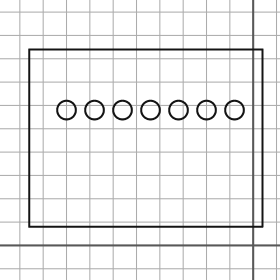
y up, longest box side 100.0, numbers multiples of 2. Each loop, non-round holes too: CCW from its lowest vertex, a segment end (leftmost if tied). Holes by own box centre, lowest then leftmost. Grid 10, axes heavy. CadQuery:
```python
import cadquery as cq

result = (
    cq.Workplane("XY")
    .moveTo(-96.0, 8.0)
    .lineTo(4.0, 8.0)
    .lineTo(4.0, 84.0)
    .lineTo(-96.0, 84.0)
    .close()
    .moveTo(-80.0, 58.0)
    .circle(4.0)
    .moveTo(-68.0, 58.0)
    .circle(4.0)
    .moveTo(-56.0, 58.0)
    .circle(4.0)
    .moveTo(-44.0, 58.0)
    .circle(4.0)
    .moveTo(-32.0, 58.0)
    .circle(4.0)
    .moveTo(-20.0, 58.0)
    .circle(4.0)
    .moveTo(-8.0, 58.0)
    .circle(4.0)
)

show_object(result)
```